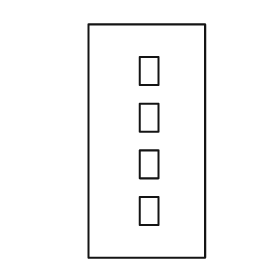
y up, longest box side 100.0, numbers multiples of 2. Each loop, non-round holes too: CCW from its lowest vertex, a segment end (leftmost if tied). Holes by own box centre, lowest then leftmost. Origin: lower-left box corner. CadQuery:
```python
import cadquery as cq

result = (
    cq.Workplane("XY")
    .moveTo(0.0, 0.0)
    .lineTo(50.0, 0.0)
    .lineTo(50.0, 100.0)
    .lineTo(0.0, 100.0)
    .close()
    .moveTo(22.0, 14.0)
    .lineTo(30.0, 14.0)
    .lineTo(30.0, 26.0)
    .lineTo(22.0, 26.0)
    .close()
    .moveTo(22.0, 34.0)
    .lineTo(30.0, 34.0)
    .lineTo(30.0, 46.0)
    .lineTo(22.0, 46.0)
    .close()
    .moveTo(22.0, 54.0)
    .lineTo(30.0, 54.0)
    .lineTo(30.0, 66.0)
    .lineTo(22.0, 66.0)
    .close()
    .moveTo(22.0, 74.0)
    .lineTo(30.0, 74.0)
    .lineTo(30.0, 86.0)
    .lineTo(22.0, 86.0)
    .close()
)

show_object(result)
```